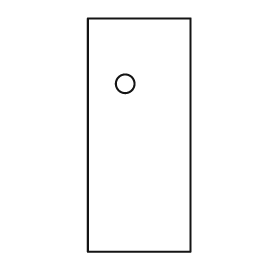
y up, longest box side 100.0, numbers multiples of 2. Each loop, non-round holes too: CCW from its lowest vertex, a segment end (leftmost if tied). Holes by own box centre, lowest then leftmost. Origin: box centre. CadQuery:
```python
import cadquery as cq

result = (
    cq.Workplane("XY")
    .moveTo(-22.0, -50.0)
    .lineTo(22.0, -50.0)
    .lineTo(22.0, 50.0)
    .lineTo(-22.0, 50.0)
    .close()
    .moveTo(-6.0, 22.0)
    .circle(4.0)
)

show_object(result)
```